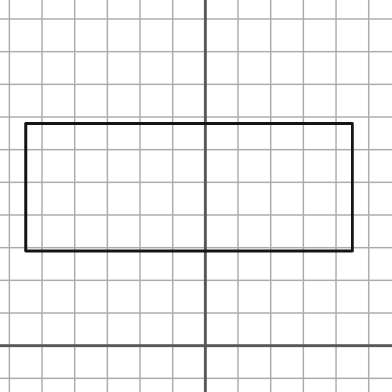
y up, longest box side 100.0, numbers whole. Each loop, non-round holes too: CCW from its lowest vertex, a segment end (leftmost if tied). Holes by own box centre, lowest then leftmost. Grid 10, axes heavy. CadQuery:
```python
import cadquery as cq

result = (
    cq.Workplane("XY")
    .moveTo(-55.0, 29.0)
    .lineTo(45.0, 29.0)
    .lineTo(45.0, 68.0)
    .lineTo(-55.0, 68.0)
    .close()
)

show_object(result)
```